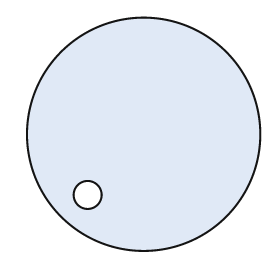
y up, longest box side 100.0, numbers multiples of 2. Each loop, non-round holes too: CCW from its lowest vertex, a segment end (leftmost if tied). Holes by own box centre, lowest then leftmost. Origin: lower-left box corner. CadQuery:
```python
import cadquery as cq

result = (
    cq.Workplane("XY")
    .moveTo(50.0, 50.0)
    .circle(50.0)
    .moveTo(26.0, 24.0)
    .circle(6.0)
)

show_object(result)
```